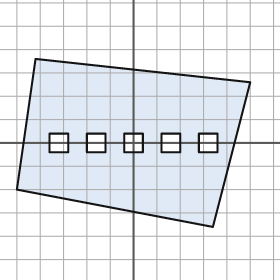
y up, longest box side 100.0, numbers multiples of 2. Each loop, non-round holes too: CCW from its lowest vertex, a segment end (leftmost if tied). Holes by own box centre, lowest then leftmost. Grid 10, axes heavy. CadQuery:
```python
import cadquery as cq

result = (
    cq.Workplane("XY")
    .moveTo(34.0, -36.0)
    .lineTo(50.0, 26.0)
    .lineTo(-42.0, 36.0)
    .lineTo(-50.0, -20.0)
    .close()
    .moveTo(-36.0, -4.0)
    .lineTo(-28.0, -4.0)
    .lineTo(-28.0, 4.0)
    .lineTo(-36.0, 4.0)
    .close()
    .moveTo(-20.0, -4.0)
    .lineTo(-12.0, -4.0)
    .lineTo(-12.0, 4.0)
    .lineTo(-20.0, 4.0)
    .close()
    .moveTo(-4.0, -4.0)
    .lineTo(4.0, -4.0)
    .lineTo(4.0, 4.0)
    .lineTo(-4.0, 4.0)
    .close()
    .moveTo(12.0, -4.0)
    .lineTo(20.0, -4.0)
    .lineTo(20.0, 4.0)
    .lineTo(12.0, 4.0)
    .close()
    .moveTo(28.0, -4.0)
    .lineTo(36.0, -4.0)
    .lineTo(36.0, 4.0)
    .lineTo(28.0, 4.0)
    .close()
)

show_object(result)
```